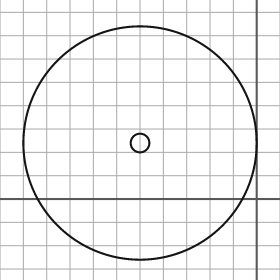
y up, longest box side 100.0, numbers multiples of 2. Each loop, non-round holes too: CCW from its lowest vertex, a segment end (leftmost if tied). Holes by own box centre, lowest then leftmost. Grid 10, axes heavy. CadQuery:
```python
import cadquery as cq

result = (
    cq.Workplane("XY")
    .moveTo(-50.0, 24.0)
    .circle(50.0)
    .moveTo(-50.0, 24.0)
    .circle(4.0)
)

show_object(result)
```